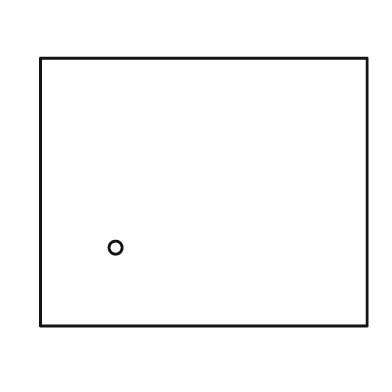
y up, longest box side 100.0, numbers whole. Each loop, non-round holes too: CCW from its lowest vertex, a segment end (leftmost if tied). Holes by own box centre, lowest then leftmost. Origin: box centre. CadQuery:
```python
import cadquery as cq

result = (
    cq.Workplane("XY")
    .moveTo(-50.0, -41.0)
    .lineTo(50.0, -41.0)
    .lineTo(50.0, 41.0)
    .lineTo(-50.0, 41.0)
    .close()
    .moveTo(-27.0, -17.0)
    .circle(2.0)
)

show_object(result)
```